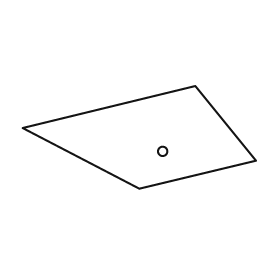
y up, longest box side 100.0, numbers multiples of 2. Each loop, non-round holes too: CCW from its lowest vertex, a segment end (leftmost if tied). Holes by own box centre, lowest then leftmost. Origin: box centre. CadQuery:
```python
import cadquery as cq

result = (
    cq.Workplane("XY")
    .moveTo(0.0, -22.0)
    .lineTo(50.0, -10.0)
    .lineTo(24.0, 22.0)
    .lineTo(-50.0, 4.0)
    .close()
    .moveTo(10.0, -6.0)
    .circle(2.0)
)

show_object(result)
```